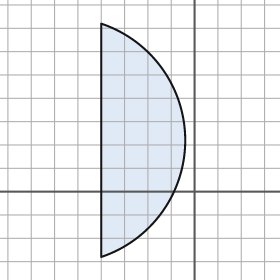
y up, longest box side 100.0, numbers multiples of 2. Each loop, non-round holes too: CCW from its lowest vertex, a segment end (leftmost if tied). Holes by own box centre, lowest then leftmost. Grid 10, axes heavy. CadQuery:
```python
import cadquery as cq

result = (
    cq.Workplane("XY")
    .moveTo(-40.0, -28.0)
    .threePointArc((-4.0, 22.0), (-40.0, 72.0))
    .close()
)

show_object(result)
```